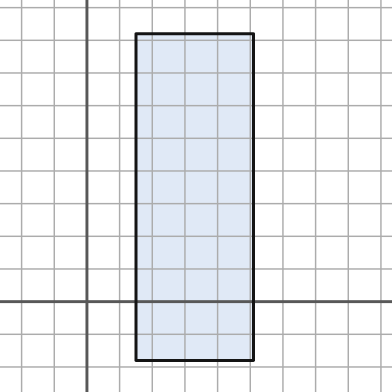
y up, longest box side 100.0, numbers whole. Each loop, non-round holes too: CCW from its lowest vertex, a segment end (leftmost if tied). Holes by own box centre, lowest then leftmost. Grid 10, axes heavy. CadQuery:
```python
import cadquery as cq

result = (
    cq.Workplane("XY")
    .moveTo(15.0, -18.0)
    .lineTo(51.0, -18.0)
    .lineTo(51.0, 82.0)
    .lineTo(15.0, 82.0)
    .close()
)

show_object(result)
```